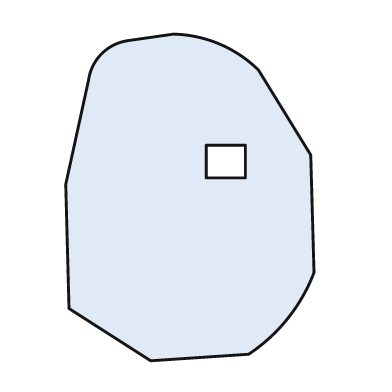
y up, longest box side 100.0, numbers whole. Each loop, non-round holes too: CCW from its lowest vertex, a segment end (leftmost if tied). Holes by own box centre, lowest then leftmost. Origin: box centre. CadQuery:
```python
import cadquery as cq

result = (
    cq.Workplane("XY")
    .moveTo(-12.0, -50.0)
    .lineTo(18.0, -48.0)
    .threePointArc((30.0, -37.0), (38.0, -23.0))
    .lineTo(37.0, 13.0)
    .lineTo(21.0, 39.0)
    .threePointArc((9.0, 47.0), (-5.0, 50.0))
    .lineTo(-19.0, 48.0)
    .threePointArc((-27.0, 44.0), (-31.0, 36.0))
    .lineTo(-38.0, 4.0)
    .lineTo(-37.0, -34.0)
    .close()
    .moveTo(5.0, 6.0)
    .lineTo(17.0, 6.0)
    .lineTo(17.0, 16.0)
    .lineTo(5.0, 16.0)
    .close()
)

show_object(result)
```